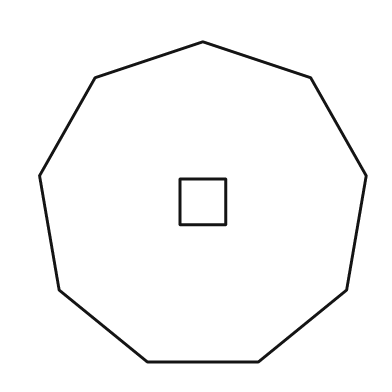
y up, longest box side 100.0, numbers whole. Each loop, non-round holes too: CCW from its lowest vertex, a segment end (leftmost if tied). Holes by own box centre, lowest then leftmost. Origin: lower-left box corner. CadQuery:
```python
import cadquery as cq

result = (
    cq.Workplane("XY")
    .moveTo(33.0, 0.0)
    .lineTo(67.0, 0.0)
    .lineTo(94.0, 22.0)
    .lineTo(100.0, 57.0)
    .lineTo(83.0, 87.0)
    .lineTo(50.0, 98.0)
    .lineTo(17.0, 87.0)
    .lineTo(0.0, 57.0)
    .lineTo(6.0, 22.0)
    .close()
    .moveTo(43.0, 42.0)
    .lineTo(57.0, 42.0)
    .lineTo(57.0, 56.0)
    .lineTo(43.0, 56.0)
    .close()
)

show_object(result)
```